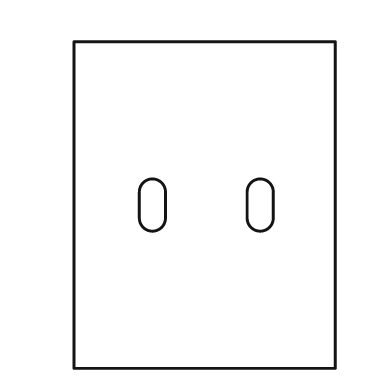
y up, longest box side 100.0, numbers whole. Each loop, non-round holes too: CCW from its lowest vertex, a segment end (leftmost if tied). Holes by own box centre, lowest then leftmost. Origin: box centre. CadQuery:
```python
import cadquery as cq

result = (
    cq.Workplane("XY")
    .moveTo(-40.0, -50.0)
    .lineTo(40.0, -50.0)
    .lineTo(40.0, 50.0)
    .lineTo(-40.0, 50.0)
    .close()
    .moveTo(-20.0, -4.0)
    .threePointArc((-16.0, -8.0), (-12.0, -4.0))
    .lineTo(-12.0, 4.0)
    .threePointArc((-16.0, 8.0), (-20.0, 4.0))
    .close()
    .moveTo(13.0, -4.0)
    .threePointArc((17.0, -8.0), (21.0, -4.0))
    .lineTo(21.0, 4.0)
    .threePointArc((17.0, 8.0), (13.0, 4.0))
    .close()
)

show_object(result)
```